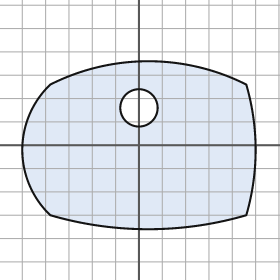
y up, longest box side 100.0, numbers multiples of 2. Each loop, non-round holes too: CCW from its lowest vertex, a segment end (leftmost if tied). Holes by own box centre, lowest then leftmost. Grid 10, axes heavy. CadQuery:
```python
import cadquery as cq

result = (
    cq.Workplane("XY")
    .moveTo(-38.0, -30.0)
    .threePointArc((4.0, -36.0), (46.0, -30.0))
    .threePointArc((50.0, -2.0), (46.0, 26.0))
    .threePointArc((4.0, 36.0), (-38.0, 26.0))
    .threePointArc((-50.0, -2.0), (-38.0, -30.0))
    .close()
    .moveTo(0.0, 16.0)
    .circle(8.0)
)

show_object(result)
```